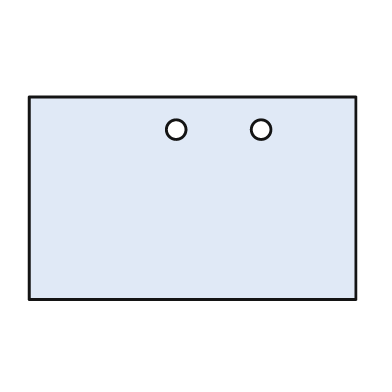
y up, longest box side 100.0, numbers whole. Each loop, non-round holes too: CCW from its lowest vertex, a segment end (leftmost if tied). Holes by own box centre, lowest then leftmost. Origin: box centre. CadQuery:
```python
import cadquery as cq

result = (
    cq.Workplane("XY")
    .moveTo(-50.0, -31.0)
    .lineTo(50.0, -31.0)
    .lineTo(50.0, 31.0)
    .lineTo(-50.0, 31.0)
    .close()
    .moveTo(-5.0, 21.0)
    .circle(3.0)
    .moveTo(21.0, 21.0)
    .circle(3.0)
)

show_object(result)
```